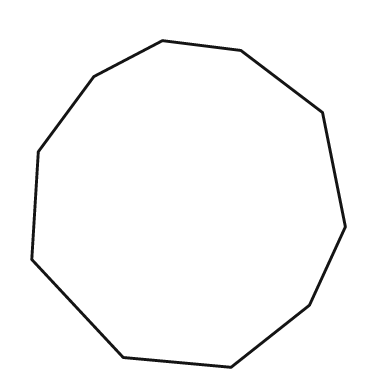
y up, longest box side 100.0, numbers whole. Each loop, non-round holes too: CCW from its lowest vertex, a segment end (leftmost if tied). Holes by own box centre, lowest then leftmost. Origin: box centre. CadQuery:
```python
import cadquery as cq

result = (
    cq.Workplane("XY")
    .moveTo(13.0, -50.0)
    .lineTo(37.0, -31.0)
    .lineTo(48.0, -7.0)
    .lineTo(41.0, 28.0)
    .lineTo(16.0, 47.0)
    .lineTo(-8.0, 50.0)
    .lineTo(-29.0, 39.0)
    .lineTo(-46.0, 16.0)
    .lineTo(-48.0, -17.0)
    .lineTo(-20.0, -47.0)
    .close()
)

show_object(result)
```